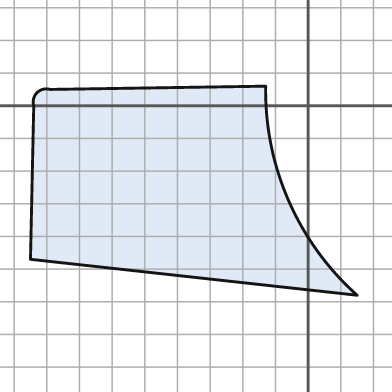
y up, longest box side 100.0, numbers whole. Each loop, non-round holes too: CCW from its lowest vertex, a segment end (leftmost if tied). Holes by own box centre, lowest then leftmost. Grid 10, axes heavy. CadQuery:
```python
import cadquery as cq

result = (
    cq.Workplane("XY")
    .moveTo(15.0, -58.0)
    .threePointArc((-6.0, -29.0), (-13.0, 6.0))
    .lineTo(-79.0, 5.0)
    .threePointArc((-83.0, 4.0), (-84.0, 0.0))
    .lineTo(-85.0, -47.0)
    .close()
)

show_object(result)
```